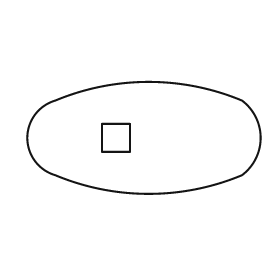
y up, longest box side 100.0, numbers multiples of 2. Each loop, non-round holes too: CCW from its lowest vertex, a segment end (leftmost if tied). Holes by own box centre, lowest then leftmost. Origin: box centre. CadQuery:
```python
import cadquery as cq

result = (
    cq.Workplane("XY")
    .moveTo(-38.0, -16.0)
    .threePointArc((2.0, -24.0), (42.0, -16.0))
    .threePointArc((50.0, 0.0), (42.0, 16.0))
    .threePointArc((2.0, 24.0), (-38.0, 16.0))
    .threePointArc((-50.0, 0.0), (-38.0, -16.0))
    .close()
    .moveTo(-18.0, -6.0)
    .lineTo(-6.0, -6.0)
    .lineTo(-6.0, 6.0)
    .lineTo(-18.0, 6.0)
    .close()
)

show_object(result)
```